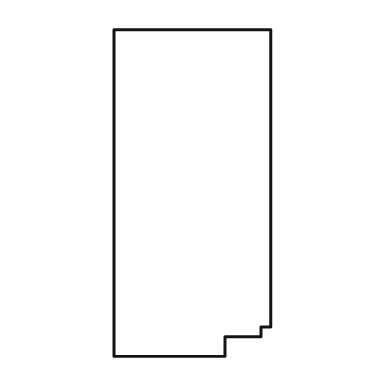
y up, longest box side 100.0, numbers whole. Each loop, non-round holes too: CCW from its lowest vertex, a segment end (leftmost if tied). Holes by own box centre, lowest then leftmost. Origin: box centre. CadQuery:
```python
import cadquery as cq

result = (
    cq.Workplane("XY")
    .moveTo(-24.0, -50.0)
    .lineTo(10.0, -50.0)
    .lineTo(10.0, -44.0)
    .lineTo(21.0, -44.0)
    .lineTo(21.0, -41.0)
    .lineTo(24.0, -41.0)
    .lineTo(24.0, 50.0)
    .lineTo(-24.0, 50.0)
    .close()
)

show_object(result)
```